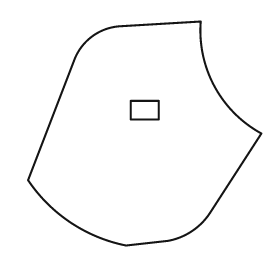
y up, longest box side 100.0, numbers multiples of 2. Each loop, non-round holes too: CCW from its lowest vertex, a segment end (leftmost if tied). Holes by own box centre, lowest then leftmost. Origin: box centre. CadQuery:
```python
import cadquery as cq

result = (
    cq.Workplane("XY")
    .moveTo(-8.0, -48.0)
    .lineTo(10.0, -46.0)
    .threePointArc((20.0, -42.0), (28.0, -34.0))
    .lineTo(50.0, 0.0)
    .threePointArc((30.0, 20.0), (24.0, 48.0))
    .lineTo(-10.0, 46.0)
    .threePointArc((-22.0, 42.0), (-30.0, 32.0))
    .lineTo(-50.0, -20.0)
    .threePointArc((-32.0, -38.0), (-8.0, -48.0))
    .close()
    .moveTo(-6.0, 6.0)
    .lineTo(6.0, 6.0)
    .lineTo(6.0, 14.0)
    .lineTo(-6.0, 14.0)
    .close()
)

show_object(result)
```